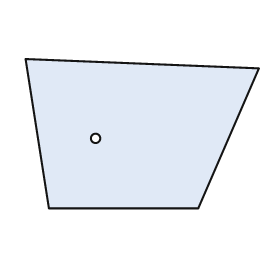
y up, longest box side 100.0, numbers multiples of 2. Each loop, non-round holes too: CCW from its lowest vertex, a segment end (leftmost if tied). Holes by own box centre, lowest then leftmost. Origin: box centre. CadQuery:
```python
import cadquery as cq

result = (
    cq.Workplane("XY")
    .moveTo(-40.0, -32.0)
    .lineTo(24.0, -32.0)
    .lineTo(50.0, 28.0)
    .lineTo(-50.0, 32.0)
    .close()
    .moveTo(-20.0, -2.0)
    .circle(2.0)
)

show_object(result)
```